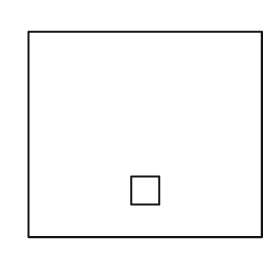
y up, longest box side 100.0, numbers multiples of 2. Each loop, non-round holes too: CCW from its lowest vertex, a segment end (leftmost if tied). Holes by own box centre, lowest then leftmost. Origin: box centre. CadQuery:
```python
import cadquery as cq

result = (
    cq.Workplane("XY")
    .moveTo(-50.0, -44.0)
    .lineTo(50.0, -44.0)
    .lineTo(50.0, 44.0)
    .lineTo(-50.0, 44.0)
    .close()
    .moveTo(-6.0, -30.0)
    .lineTo(6.0, -30.0)
    .lineTo(6.0, -18.0)
    .lineTo(-6.0, -18.0)
    .close()
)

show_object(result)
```